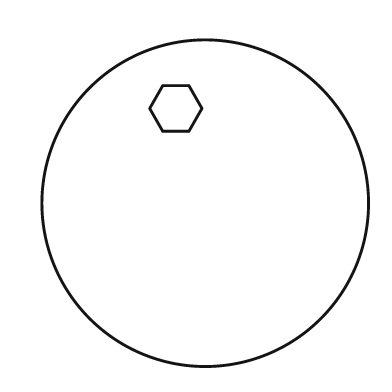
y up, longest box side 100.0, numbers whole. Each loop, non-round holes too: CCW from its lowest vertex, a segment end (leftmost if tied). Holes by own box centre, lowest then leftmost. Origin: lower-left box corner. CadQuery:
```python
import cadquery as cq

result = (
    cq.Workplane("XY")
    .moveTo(50.0, 50.0)
    .circle(50.0)
    .moveTo(37.0, 72.0)
    .lineTo(45.0, 72.0)
    .lineTo(49.0, 79.0)
    .lineTo(45.0, 86.0)
    .lineTo(37.0, 86.0)
    .lineTo(33.0, 79.0)
    .close()
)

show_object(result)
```